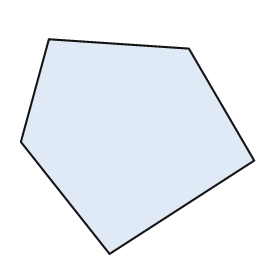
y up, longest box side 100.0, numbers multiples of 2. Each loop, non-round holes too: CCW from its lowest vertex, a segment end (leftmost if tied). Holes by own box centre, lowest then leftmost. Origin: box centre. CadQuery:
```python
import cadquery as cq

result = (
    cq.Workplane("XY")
    .moveTo(-12.0, -46.0)
    .lineTo(50.0, -6.0)
    .lineTo(22.0, 42.0)
    .lineTo(-38.0, 46.0)
    .lineTo(-50.0, 2.0)
    .close()
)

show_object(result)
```